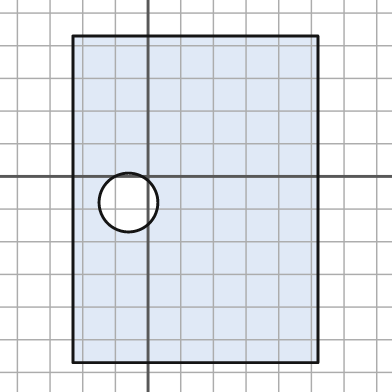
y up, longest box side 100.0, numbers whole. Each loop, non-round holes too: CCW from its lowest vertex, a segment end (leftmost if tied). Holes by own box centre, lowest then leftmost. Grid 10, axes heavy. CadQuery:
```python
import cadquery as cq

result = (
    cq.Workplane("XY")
    .moveTo(-23.0, -57.0)
    .lineTo(52.0, -57.0)
    .lineTo(52.0, 43.0)
    .lineTo(-23.0, 43.0)
    .close()
    .moveTo(-6.0, -8.0)
    .circle(9.0)
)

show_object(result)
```